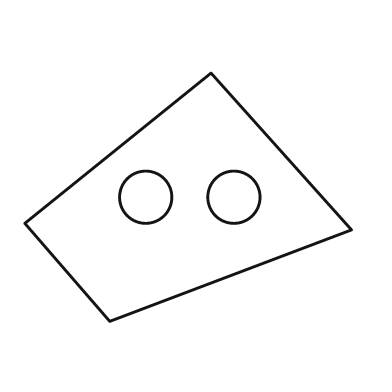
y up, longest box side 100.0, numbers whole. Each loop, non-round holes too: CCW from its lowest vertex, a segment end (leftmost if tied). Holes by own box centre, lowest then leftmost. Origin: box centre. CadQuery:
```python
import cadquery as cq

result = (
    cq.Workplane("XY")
    .moveTo(-24.0, -38.0)
    .lineTo(50.0, -10.0)
    .lineTo(7.0, 38.0)
    .lineTo(-50.0, -8.0)
    .close()
    .moveTo(-13.0, 0.0)
    .circle(8.0)
    .moveTo(14.0, 0.0)
    .circle(8.0)
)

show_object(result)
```